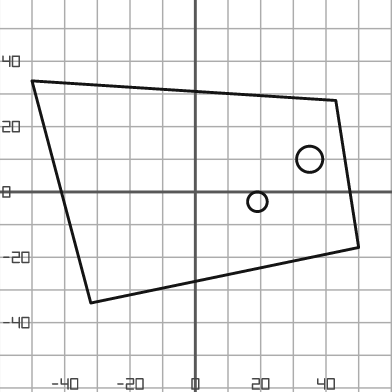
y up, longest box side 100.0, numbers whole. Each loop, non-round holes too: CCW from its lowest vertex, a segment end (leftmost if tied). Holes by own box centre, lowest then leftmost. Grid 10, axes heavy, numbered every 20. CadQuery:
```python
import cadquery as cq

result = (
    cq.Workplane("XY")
    .moveTo(-32.0, -34.0)
    .lineTo(50.0, -17.0)
    .lineTo(43.0, 28.0)
    .lineTo(-50.0, 34.0)
    .close()
    .moveTo(19.0, -3.0)
    .circle(3.0)
    .moveTo(35.0, 10.0)
    .circle(4.0)
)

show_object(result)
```